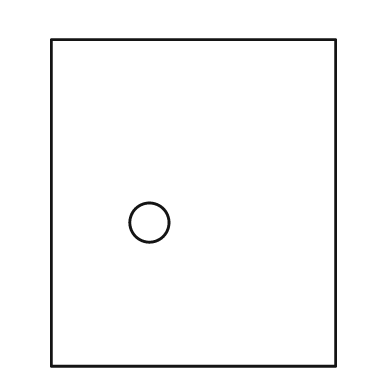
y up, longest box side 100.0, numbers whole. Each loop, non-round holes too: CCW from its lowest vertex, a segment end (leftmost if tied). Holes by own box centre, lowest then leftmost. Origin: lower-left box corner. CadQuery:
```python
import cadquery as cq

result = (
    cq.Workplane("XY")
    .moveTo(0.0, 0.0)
    .lineTo(87.0, 0.0)
    .lineTo(87.0, 100.0)
    .lineTo(0.0, 100.0)
    .close()
    .moveTo(30.0, 44.0)
    .circle(6.0)
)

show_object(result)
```